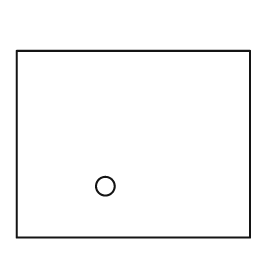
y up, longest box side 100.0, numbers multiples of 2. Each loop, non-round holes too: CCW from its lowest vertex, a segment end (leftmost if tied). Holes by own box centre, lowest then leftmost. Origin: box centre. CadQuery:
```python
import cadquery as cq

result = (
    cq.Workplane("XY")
    .moveTo(-50.0, -40.0)
    .lineTo(50.0, -40.0)
    .lineTo(50.0, 40.0)
    .lineTo(-50.0, 40.0)
    .close()
    .moveTo(-12.0, -18.0)
    .circle(4.0)
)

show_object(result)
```